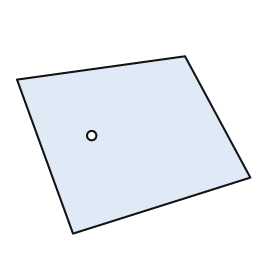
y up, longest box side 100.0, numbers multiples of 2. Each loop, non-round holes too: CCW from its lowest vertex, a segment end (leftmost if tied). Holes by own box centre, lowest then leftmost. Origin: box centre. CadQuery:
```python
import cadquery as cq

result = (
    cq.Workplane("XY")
    .moveTo(-26.0, -38.0)
    .lineTo(50.0, -14.0)
    .lineTo(22.0, 38.0)
    .lineTo(-50.0, 28.0)
    .close()
    .moveTo(-18.0, 4.0)
    .circle(2.0)
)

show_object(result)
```